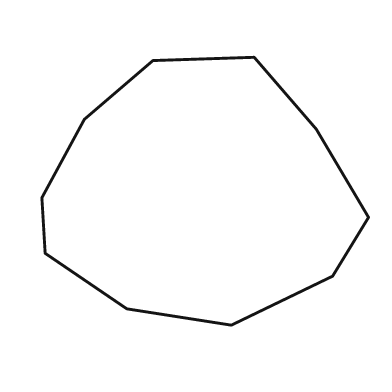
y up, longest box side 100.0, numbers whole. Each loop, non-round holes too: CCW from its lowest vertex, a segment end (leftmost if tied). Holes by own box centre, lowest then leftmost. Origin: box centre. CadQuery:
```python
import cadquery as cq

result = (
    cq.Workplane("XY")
    .moveTo(8.0, -41.0)
    .lineTo(39.0, -26.0)
    .lineTo(50.0, -8.0)
    .lineTo(34.0, 19.0)
    .lineTo(15.0, 41.0)
    .lineTo(-16.0, 40.0)
    .lineTo(-37.0, 22.0)
    .lineTo(-50.0, -2.0)
    .lineTo(-49.0, -19.0)
    .lineTo(-24.0, -36.0)
    .close()
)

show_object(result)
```